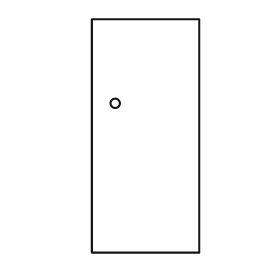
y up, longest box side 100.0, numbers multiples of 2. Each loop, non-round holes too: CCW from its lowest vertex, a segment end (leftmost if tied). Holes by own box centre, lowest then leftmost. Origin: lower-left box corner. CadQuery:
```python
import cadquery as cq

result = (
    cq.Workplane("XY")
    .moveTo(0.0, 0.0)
    .lineTo(46.0, 0.0)
    .lineTo(46.0, 100.0)
    .lineTo(0.0, 100.0)
    .close()
    .moveTo(10.0, 64.0)
    .circle(2.0)
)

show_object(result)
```